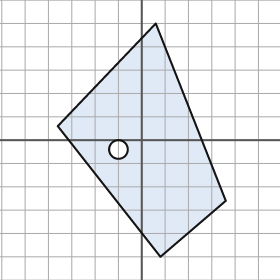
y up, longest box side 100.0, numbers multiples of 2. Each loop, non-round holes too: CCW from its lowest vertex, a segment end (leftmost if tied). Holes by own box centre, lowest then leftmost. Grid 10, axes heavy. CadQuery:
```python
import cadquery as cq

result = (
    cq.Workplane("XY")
    .moveTo(8.0, -50.0)
    .lineTo(36.0, -26.0)
    .lineTo(6.0, 50.0)
    .lineTo(-36.0, 6.0)
    .close()
    .moveTo(-10.0, -4.0)
    .circle(4.0)
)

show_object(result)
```